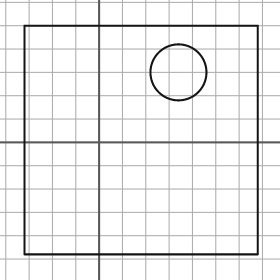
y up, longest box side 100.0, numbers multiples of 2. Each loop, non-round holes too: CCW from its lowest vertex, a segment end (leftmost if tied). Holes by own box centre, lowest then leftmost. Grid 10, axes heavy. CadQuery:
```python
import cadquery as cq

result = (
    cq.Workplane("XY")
    .moveTo(-32.0, -48.0)
    .lineTo(68.0, -48.0)
    .lineTo(68.0, 50.0)
    .lineTo(-32.0, 50.0)
    .close()
    .moveTo(34.0, 30.0)
    .circle(12.0)
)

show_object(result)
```